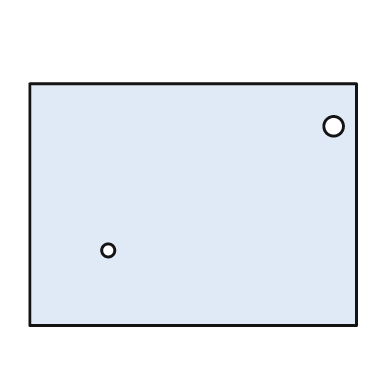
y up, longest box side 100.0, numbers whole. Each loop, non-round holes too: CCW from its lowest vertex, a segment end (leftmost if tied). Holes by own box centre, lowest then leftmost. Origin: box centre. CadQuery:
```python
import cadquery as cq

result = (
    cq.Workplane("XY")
    .moveTo(-50.0, -37.0)
    .lineTo(50.0, -37.0)
    .lineTo(50.0, 37.0)
    .lineTo(-50.0, 37.0)
    .close()
    .moveTo(-26.0, -14.0)
    .circle(2.0)
    .moveTo(43.0, 24.0)
    .circle(3.0)
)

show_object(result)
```